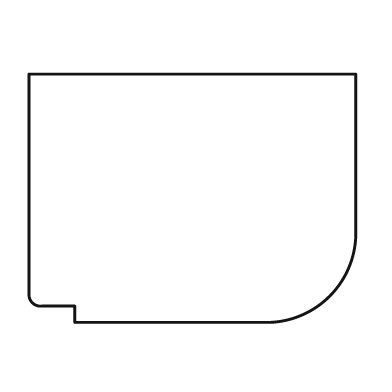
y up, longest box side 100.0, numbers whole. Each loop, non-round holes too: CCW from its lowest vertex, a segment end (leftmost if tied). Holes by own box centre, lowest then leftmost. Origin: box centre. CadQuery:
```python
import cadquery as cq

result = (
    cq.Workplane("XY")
    .moveTo(-36.0, -38.0)
    .lineTo(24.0, -38.0)
    .threePointArc((42.0, -30.0), (50.0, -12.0))
    .lineTo(50.0, 38.0)
    .lineTo(-50.0, 38.0)
    .lineTo(-50.0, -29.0)
    .threePointArc((-49.0, -32.0), (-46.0, -33.0))
    .lineTo(-36.0, -33.0)
    .close()
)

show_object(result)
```